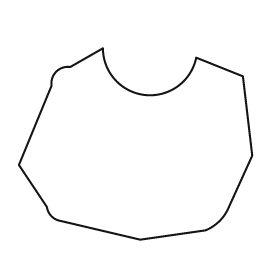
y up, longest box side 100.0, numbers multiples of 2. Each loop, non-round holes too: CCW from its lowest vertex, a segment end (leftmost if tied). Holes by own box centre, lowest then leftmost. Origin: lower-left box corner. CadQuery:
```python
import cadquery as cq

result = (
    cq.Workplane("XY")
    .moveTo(52.0, 0.0)
    .lineTo(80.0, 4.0)
    .threePointArc((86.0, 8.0), (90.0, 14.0))
    .lineTo(100.0, 36.0)
    .lineTo(96.0, 70.0)
    .lineTo(76.0, 78.0)
    .threePointArc((54.0, 62.0), (36.0, 82.0))
    .lineTo(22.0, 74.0)
    .threePointArc((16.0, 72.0), (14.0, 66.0))
    .lineTo(0.0, 32.0)
    .lineTo(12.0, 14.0)
    .threePointArc((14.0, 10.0), (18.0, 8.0))
    .close()
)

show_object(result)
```